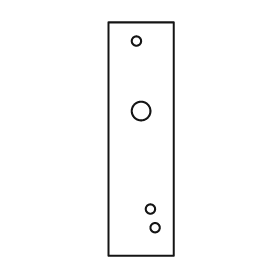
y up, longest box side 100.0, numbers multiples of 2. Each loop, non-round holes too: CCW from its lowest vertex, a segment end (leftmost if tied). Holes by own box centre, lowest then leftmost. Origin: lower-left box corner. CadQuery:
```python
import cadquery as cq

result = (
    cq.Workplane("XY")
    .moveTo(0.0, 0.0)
    .lineTo(28.0, 0.0)
    .lineTo(28.0, 100.0)
    .lineTo(0.0, 100.0)
    .close()
    .moveTo(20.0, 12.0)
    .circle(2.0)
    .moveTo(18.0, 20.0)
    .circle(2.0)
    .moveTo(14.0, 62.0)
    .circle(4.0)
    .moveTo(12.0, 92.0)
    .circle(2.0)
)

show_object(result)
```